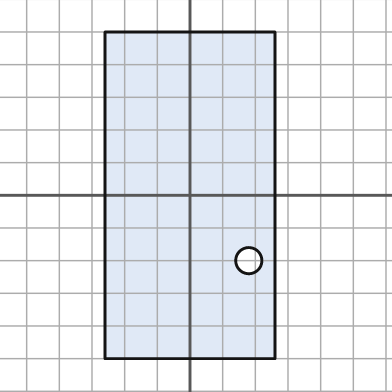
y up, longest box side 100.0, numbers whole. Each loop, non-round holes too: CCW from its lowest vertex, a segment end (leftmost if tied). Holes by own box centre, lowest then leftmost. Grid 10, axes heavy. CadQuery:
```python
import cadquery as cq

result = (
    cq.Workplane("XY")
    .moveTo(-26.0, -50.0)
    .lineTo(26.0, -50.0)
    .lineTo(26.0, 50.0)
    .lineTo(-26.0, 50.0)
    .close()
    .moveTo(18.0, -20.0)
    .circle(4.0)
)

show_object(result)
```